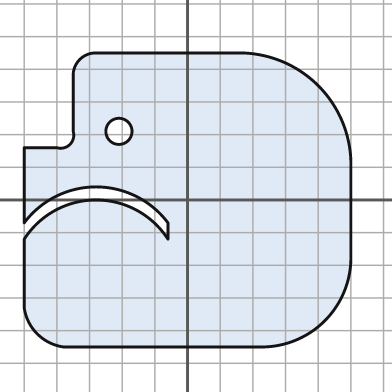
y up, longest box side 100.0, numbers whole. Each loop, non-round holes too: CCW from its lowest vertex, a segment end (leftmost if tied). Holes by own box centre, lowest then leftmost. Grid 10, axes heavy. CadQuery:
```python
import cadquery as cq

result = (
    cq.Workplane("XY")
    .moveTo(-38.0, -45.0)
    .lineTo(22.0, -45.0)
    .threePointArc((42.0, -37.0), (50.0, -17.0))
    .lineTo(50.0, 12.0)
    .threePointArc((40.0, 35.0), (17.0, 45.0))
    .lineTo(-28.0, 45.0)
    .threePointArc((-33.0, 43.0), (-35.0, 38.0))
    .lineTo(-35.0, 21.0)
    .threePointArc((-36.0, 17.0), (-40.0, 16.0))
    .lineTo(-50.0, 16.0)
    .lineTo(-50.0, -7.0)
    .threePointArc((-28.0, 4.0), (-6.0, -7.0))
    .lineTo(-6.0, -12.0)
    .threePointArc((-28.0, 0.0), (-50.0, -12.0))
    .lineTo(-50.0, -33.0)
    .threePointArc((-46.0, -41.0), (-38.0, -45.0))
    .close()
    .moveTo(-21.0, 21.0)
    .circle(4.0)
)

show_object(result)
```